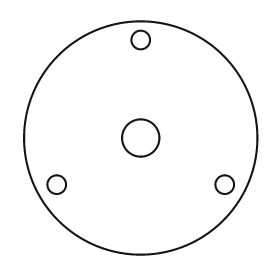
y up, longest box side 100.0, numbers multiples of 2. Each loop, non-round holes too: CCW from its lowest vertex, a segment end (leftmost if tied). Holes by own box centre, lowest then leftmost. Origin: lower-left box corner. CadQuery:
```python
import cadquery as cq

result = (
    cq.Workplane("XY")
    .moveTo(50.0, 50.0)
    .circle(50.0)
    .moveTo(14.0, 30.0)
    .circle(4.0)
    .moveTo(86.0, 30.0)
    .circle(4.0)
    .moveTo(50.0, 50.0)
    .circle(8.0)
    .moveTo(50.0, 92.0)
    .circle(4.0)
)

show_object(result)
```